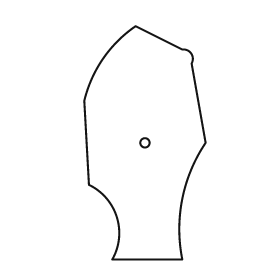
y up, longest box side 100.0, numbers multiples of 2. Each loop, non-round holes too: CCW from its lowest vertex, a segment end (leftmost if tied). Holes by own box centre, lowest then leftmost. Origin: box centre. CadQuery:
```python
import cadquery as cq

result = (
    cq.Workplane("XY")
    .moveTo(-14.0, -50.0)
    .lineTo(16.0, -50.0)
    .threePointArc((16.0, -24.0), (26.0, 0.0))
    .lineTo(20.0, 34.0)
    .threePointArc((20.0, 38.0), (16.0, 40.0))
    .lineTo(-4.0, 50.0)
    .threePointArc((-18.0, 36.0), (-26.0, 18.0))
    .lineTo(-24.0, -18.0)
    .threePointArc((-12.0, -32.0), (-14.0, -50.0))
    .close()
    .moveTo(0.0, 0.0)
    .circle(2.0)
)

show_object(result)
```